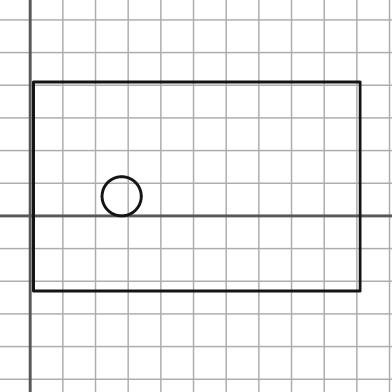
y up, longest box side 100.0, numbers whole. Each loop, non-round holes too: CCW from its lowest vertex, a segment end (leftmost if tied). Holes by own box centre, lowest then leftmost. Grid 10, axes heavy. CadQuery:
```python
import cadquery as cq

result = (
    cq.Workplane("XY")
    .moveTo(1.0, -23.0)
    .lineTo(101.0, -23.0)
    .lineTo(101.0, 41.0)
    .lineTo(1.0, 41.0)
    .close()
    .moveTo(28.0, 6.0)
    .circle(6.0)
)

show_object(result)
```